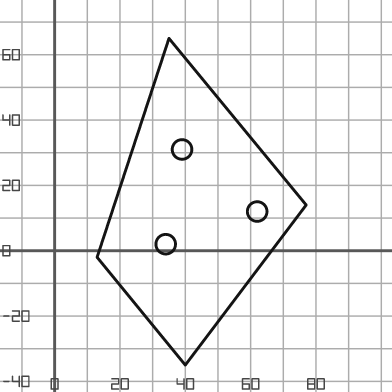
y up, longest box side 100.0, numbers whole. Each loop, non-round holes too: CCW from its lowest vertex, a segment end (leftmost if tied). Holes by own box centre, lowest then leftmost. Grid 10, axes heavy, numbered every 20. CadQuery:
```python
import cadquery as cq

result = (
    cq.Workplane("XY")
    .moveTo(40.0, -35.0)
    .lineTo(77.0, 14.0)
    .lineTo(35.0, 65.0)
    .lineTo(13.0, -2.0)
    .close()
    .moveTo(34.0, 2.0)
    .circle(3.0)
    .moveTo(62.0, 12.0)
    .circle(3.0)
    .moveTo(39.0, 31.0)
    .circle(3.0)
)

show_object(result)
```